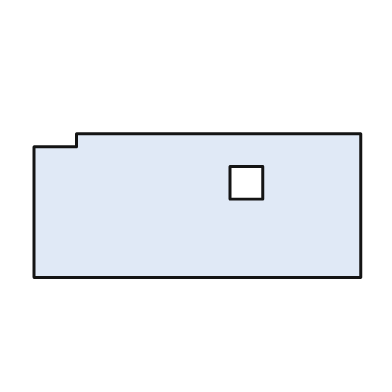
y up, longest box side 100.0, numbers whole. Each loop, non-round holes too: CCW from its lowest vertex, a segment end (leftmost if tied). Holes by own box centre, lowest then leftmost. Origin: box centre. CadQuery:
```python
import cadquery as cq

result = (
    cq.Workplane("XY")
    .moveTo(-50.0, -22.0)
    .lineTo(50.0, -22.0)
    .lineTo(50.0, 22.0)
    .lineTo(-37.0, 22.0)
    .lineTo(-37.0, 18.0)
    .lineTo(-50.0, 18.0)
    .close()
    .moveTo(10.0, 2.0)
    .lineTo(20.0, 2.0)
    .lineTo(20.0, 12.0)
    .lineTo(10.0, 12.0)
    .close()
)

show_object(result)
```